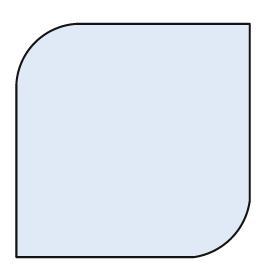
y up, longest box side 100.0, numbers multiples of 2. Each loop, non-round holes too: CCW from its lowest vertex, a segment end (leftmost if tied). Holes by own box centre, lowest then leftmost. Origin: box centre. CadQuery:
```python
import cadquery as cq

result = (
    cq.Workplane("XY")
    .moveTo(-50.0, -50.0)
    .lineTo(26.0, -50.0)
    .threePointArc((42.0, -42.0), (50.0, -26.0))
    .lineTo(50.0, 50.0)
    .lineTo(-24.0, 50.0)
    .threePointArc((-42.0, 42.0), (-50.0, 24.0))
    .close()
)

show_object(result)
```